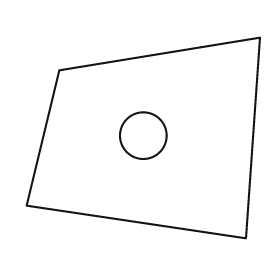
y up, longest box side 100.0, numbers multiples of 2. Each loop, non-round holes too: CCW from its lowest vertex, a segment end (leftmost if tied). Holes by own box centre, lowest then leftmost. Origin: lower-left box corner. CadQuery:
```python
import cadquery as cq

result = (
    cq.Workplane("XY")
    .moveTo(94.0, 0.0)
    .lineTo(100.0, 86.0)
    .lineTo(14.0, 72.0)
    .lineTo(0.0, 14.0)
    .close()
    .moveTo(50.0, 44.0)
    .circle(10.0)
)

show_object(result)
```